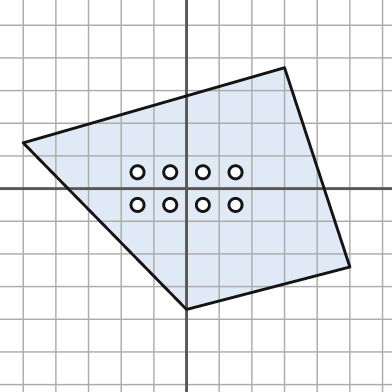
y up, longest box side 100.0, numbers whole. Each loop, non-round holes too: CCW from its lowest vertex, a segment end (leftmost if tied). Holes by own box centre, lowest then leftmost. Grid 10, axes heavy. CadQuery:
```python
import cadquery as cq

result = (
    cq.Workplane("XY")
    .moveTo(0.0, -37.0)
    .lineTo(50.0, -24.0)
    .lineTo(30.0, 37.0)
    .lineTo(-50.0, 14.0)
    .close()
    .moveTo(-15.0, -5.0)
    .circle(2.0)
    .moveTo(-5.0, -5.0)
    .circle(2.0)
    .moveTo(5.0, -5.0)
    .circle(2.0)
    .moveTo(15.0, -5.0)
    .circle(2.0)
    .moveTo(-15.0, 5.0)
    .circle(2.0)
    .moveTo(-5.0, 5.0)
    .circle(2.0)
    .moveTo(5.0, 5.0)
    .circle(2.0)
    .moveTo(15.0, 5.0)
    .circle(2.0)
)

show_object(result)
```